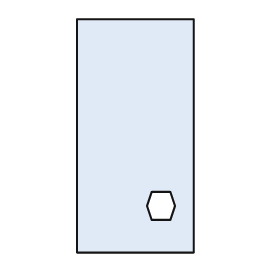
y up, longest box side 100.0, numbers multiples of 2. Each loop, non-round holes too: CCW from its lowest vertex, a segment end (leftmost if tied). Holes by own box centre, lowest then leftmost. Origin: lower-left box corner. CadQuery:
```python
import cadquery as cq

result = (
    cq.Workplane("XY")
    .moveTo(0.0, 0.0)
    .lineTo(50.0, 0.0)
    .lineTo(50.0, 100.0)
    .lineTo(0.0, 100.0)
    .close()
    .moveTo(32.0, 14.0)
    .lineTo(40.0, 14.0)
    .lineTo(42.0, 20.0)
    .lineTo(40.0, 26.0)
    .lineTo(32.0, 26.0)
    .lineTo(30.0, 20.0)
    .close()
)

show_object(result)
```